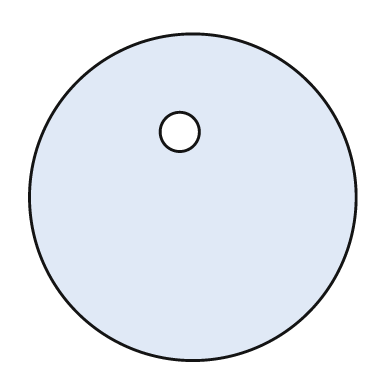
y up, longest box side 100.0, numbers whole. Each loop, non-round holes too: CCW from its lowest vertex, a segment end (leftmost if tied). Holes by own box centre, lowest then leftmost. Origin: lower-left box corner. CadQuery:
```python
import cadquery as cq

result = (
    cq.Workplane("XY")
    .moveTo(50.0, 50.0)
    .circle(50.0)
    .moveTo(46.0, 70.0)
    .circle(6.0)
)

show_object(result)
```